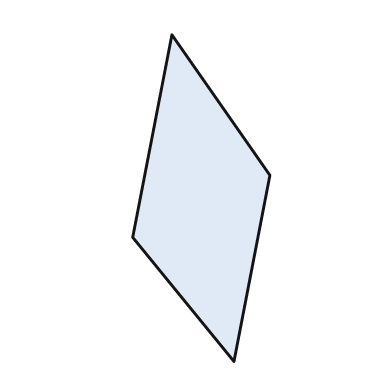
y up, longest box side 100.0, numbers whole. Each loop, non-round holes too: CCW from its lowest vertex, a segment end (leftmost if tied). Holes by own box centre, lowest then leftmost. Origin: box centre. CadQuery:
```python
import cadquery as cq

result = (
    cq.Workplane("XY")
    .moveTo(10.0, -50.0)
    .lineTo(21.0, 7.0)
    .lineTo(-9.0, 50.0)
    .lineTo(-21.0, -12.0)
    .close()
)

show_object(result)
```